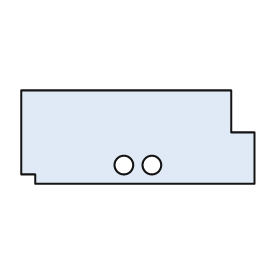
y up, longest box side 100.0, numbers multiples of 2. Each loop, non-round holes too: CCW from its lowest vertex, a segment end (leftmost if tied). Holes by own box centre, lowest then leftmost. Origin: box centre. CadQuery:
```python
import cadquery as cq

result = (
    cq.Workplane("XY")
    .moveTo(-44.0, -20.0)
    .lineTo(50.0, -20.0)
    .lineTo(50.0, 2.0)
    .lineTo(40.0, 2.0)
    .lineTo(40.0, 20.0)
    .lineTo(-50.0, 20.0)
    .lineTo(-50.0, -16.0)
    .lineTo(-44.0, -16.0)
    .close()
    .moveTo(-6.0, -12.0)
    .circle(4.0)
    .moveTo(6.0, -12.0)
    .circle(4.0)
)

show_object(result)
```